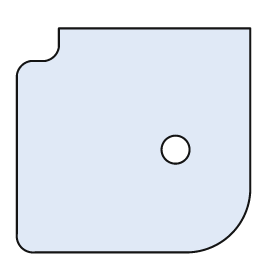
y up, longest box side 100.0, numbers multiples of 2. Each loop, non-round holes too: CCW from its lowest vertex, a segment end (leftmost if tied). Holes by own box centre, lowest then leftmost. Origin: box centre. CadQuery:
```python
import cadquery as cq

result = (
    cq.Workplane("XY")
    .moveTo(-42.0, -48.0)
    .lineTo(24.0, -48.0)
    .threePointArc((42.0, -40.0), (50.0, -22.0))
    .lineTo(50.0, 48.0)
    .lineTo(-32.0, 48.0)
    .lineTo(-32.0, 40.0)
    .threePointArc((-34.0, 36.0), (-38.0, 34.0))
    .lineTo(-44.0, 34.0)
    .threePointArc((-48.0, 32.0), (-50.0, 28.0))
    .lineTo(-50.0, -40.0)
    .threePointArc((-48.0, -46.0), (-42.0, -48.0))
    .close()
    .moveTo(18.0, -4.0)
    .circle(6.0)
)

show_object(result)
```